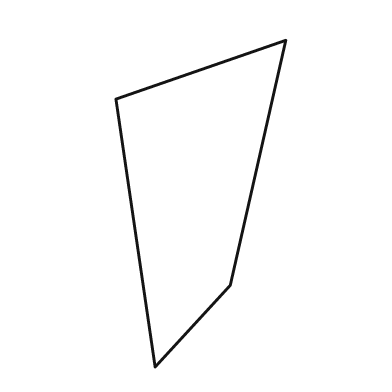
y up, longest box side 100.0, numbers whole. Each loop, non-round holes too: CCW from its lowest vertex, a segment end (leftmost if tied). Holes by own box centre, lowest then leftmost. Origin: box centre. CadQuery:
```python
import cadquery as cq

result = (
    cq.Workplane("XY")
    .moveTo(-14.0, -50.0)
    .lineTo(9.0, -25.0)
    .lineTo(26.0, 50.0)
    .lineTo(-26.0, 32.0)
    .close()
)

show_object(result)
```